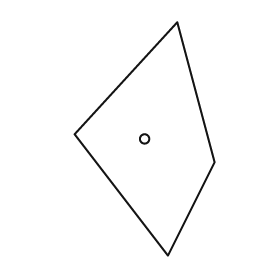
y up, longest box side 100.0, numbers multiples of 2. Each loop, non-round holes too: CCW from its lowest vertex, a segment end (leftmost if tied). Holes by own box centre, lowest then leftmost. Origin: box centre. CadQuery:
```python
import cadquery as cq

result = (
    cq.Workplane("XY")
    .moveTo(10.0, -50.0)
    .lineTo(30.0, -10.0)
    .lineTo(14.0, 50.0)
    .lineTo(-30.0, 2.0)
    .close()
    .moveTo(0.0, 0.0)
    .circle(2.0)
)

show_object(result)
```